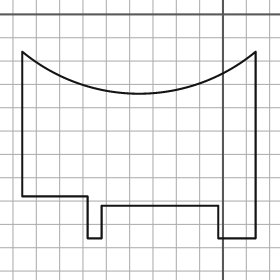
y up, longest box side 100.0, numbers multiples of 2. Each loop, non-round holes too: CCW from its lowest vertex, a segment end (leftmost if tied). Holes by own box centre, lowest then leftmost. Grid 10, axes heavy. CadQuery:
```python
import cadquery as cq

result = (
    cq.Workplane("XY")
    .moveTo(-58.0, -96.0)
    .lineTo(-52.0, -96.0)
    .lineTo(-52.0, -82.0)
    .lineTo(-2.0, -82.0)
    .lineTo(-2.0, -96.0)
    .lineTo(14.0, -96.0)
    .lineTo(14.0, -16.0)
    .threePointArc((-36.0, -34.0), (-86.0, -16.0))
    .lineTo(-86.0, -78.0)
    .lineTo(-58.0, -78.0)
    .close()
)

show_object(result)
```